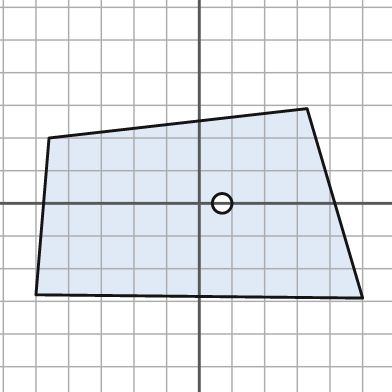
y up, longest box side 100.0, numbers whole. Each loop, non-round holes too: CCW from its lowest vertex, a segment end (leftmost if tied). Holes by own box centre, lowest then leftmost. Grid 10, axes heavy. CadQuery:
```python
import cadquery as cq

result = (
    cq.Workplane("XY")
    .moveTo(50.0, -29.0)
    .lineTo(33.0, 29.0)
    .lineTo(-46.0, 20.0)
    .lineTo(-50.0, -28.0)
    .close()
    .moveTo(7.0, 0.0)
    .circle(3.0)
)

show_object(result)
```